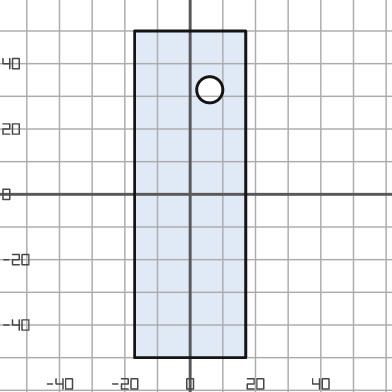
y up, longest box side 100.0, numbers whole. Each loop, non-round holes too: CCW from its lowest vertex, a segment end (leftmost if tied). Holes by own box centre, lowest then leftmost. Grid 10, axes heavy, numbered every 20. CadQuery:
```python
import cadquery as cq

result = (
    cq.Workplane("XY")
    .moveTo(-17.0, -50.0)
    .lineTo(17.0, -50.0)
    .lineTo(17.0, 50.0)
    .lineTo(-17.0, 50.0)
    .close()
    .moveTo(6.0, 32.0)
    .circle(4.0)
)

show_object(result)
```